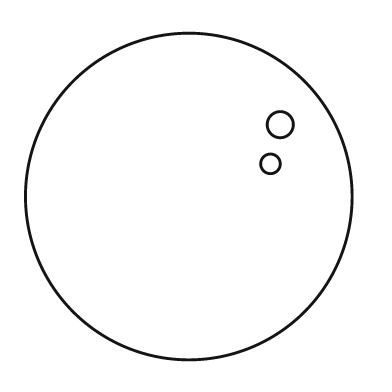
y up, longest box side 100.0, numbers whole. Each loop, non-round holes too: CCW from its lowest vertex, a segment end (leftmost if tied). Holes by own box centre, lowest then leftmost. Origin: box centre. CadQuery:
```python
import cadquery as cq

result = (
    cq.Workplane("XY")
    .moveTo(0.0, 0.0)
    .circle(50.0)
    .moveTo(25.0, 10.0)
    .circle(3.0)
    .moveTo(28.0, 22.0)
    .circle(4.0)
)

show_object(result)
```